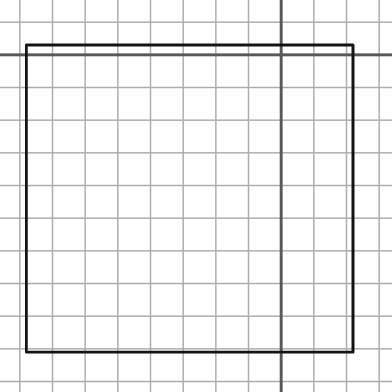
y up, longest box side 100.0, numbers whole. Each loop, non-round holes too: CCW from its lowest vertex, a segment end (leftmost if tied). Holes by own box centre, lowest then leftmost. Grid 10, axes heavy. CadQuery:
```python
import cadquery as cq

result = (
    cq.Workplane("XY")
    .moveTo(-78.0, -91.0)
    .lineTo(22.0, -91.0)
    .lineTo(22.0, 3.0)
    .lineTo(-78.0, 3.0)
    .close()
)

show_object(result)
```